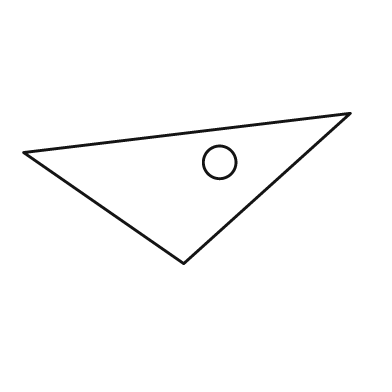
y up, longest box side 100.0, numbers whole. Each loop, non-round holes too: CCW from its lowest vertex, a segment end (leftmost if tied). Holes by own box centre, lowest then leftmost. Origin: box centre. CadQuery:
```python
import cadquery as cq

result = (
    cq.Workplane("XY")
    .moveTo(-1.0, -23.0)
    .lineTo(50.0, 23.0)
    .lineTo(-50.0, 11.0)
    .close()
    .moveTo(10.0, 8.0)
    .circle(5.0)
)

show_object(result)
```